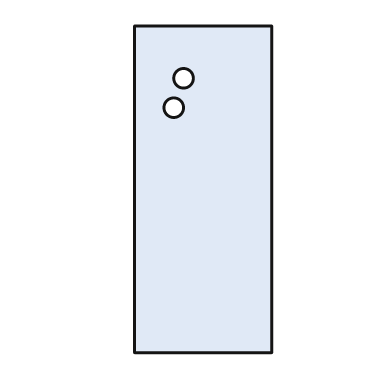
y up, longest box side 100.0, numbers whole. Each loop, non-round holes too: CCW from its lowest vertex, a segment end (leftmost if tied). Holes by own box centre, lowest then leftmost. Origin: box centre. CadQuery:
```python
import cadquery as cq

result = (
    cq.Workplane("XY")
    .moveTo(-21.0, -50.0)
    .lineTo(21.0, -50.0)
    .lineTo(21.0, 50.0)
    .lineTo(-21.0, 50.0)
    .close()
    .moveTo(-9.0, 25.0)
    .circle(3.0)
    .moveTo(-6.0, 34.0)
    .circle(3.0)
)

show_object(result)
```